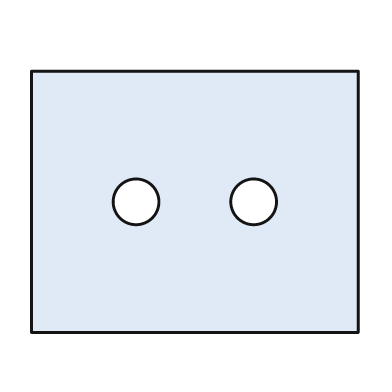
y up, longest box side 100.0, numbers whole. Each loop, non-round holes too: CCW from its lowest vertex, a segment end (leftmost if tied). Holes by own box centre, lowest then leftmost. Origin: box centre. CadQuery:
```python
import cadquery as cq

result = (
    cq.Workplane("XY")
    .moveTo(-50.0, -40.0)
    .lineTo(50.0, -40.0)
    .lineTo(50.0, 40.0)
    .lineTo(-50.0, 40.0)
    .close()
    .moveTo(-18.0, 0.0)
    .circle(7.0)
    .moveTo(18.0, 0.0)
    .circle(7.0)
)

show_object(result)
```